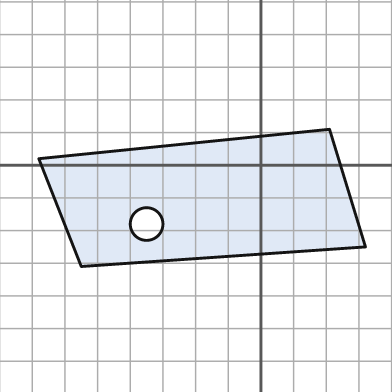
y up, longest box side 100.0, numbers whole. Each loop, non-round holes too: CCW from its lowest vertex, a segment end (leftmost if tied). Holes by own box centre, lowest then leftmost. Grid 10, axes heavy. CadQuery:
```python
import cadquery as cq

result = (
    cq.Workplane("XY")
    .moveTo(-55.0, -31.0)
    .lineTo(32.0, -25.0)
    .lineTo(21.0, 11.0)
    .lineTo(-68.0, 2.0)
    .close()
    .moveTo(-35.0, -18.0)
    .circle(5.0)
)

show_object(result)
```